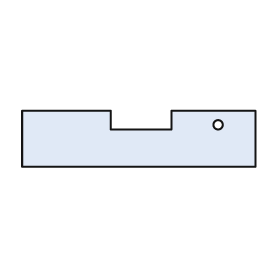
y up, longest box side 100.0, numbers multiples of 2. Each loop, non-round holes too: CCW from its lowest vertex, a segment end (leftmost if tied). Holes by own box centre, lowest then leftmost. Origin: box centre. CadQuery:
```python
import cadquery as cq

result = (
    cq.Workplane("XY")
    .moveTo(-50.0, -12.0)
    .lineTo(50.0, -12.0)
    .lineTo(50.0, 12.0)
    .lineTo(14.0, 12.0)
    .lineTo(14.0, 4.0)
    .lineTo(-12.0, 4.0)
    .lineTo(-12.0, 12.0)
    .lineTo(-50.0, 12.0)
    .close()
    .moveTo(34.0, 6.0)
    .circle(2.0)
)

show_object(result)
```